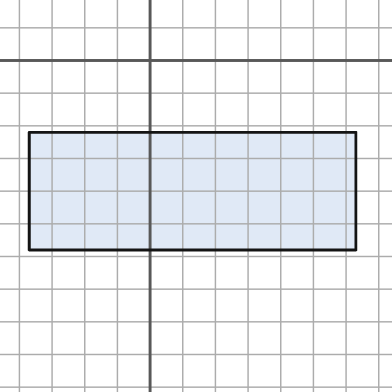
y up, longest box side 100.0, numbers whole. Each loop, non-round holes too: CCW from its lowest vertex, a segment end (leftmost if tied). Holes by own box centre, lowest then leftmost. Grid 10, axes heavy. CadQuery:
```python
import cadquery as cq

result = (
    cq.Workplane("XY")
    .moveTo(-37.0, -58.0)
    .lineTo(63.0, -58.0)
    .lineTo(63.0, -22.0)
    .lineTo(-37.0, -22.0)
    .close()
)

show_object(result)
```